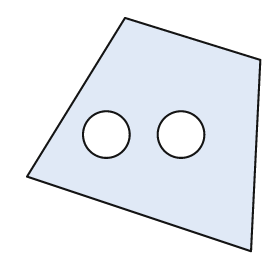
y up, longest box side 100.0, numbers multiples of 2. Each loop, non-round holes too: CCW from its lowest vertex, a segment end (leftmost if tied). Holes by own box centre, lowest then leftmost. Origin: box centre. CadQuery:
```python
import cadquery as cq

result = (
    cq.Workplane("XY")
    .moveTo(46.0, -50.0)
    .lineTo(50.0, 32.0)
    .lineTo(-8.0, 50.0)
    .lineTo(-50.0, -18.0)
    .close()
    .moveTo(-16.0, 0.0)
    .circle(10.0)
    .moveTo(16.0, 0.0)
    .circle(10.0)
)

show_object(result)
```